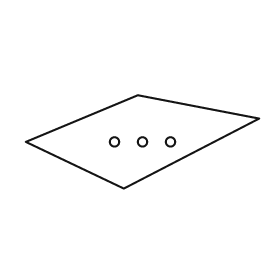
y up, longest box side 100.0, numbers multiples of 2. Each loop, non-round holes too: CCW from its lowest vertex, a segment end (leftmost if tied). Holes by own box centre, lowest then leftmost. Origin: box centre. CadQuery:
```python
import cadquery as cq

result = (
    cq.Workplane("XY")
    .moveTo(-8.0, -20.0)
    .lineTo(50.0, 10.0)
    .lineTo(-2.0, 20.0)
    .lineTo(-50.0, 0.0)
    .close()
    .moveTo(-12.0, 0.0)
    .circle(2.0)
    .moveTo(0.0, 0.0)
    .circle(2.0)
    .moveTo(12.0, 0.0)
    .circle(2.0)
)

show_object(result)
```